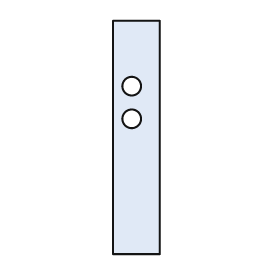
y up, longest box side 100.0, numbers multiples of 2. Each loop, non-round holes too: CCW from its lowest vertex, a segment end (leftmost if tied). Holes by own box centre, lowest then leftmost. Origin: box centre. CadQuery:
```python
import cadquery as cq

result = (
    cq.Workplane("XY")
    .moveTo(-10.0, -50.0)
    .lineTo(10.0, -50.0)
    .lineTo(10.0, 50.0)
    .lineTo(-10.0, 50.0)
    .close()
    .moveTo(-2.0, 8.0)
    .circle(4.0)
    .moveTo(-2.0, 22.0)
    .circle(4.0)
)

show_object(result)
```